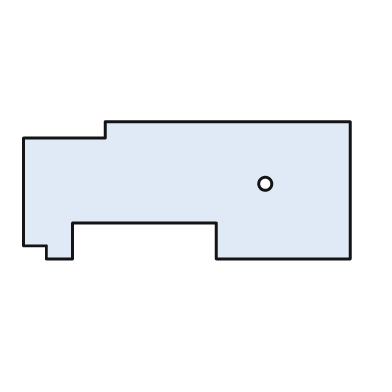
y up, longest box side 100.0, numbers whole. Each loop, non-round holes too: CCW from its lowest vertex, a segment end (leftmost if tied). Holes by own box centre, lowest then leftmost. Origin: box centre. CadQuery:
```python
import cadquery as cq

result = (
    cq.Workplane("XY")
    .moveTo(-43.0, -21.0)
    .lineTo(-35.0, -21.0)
    .lineTo(-35.0, -10.0)
    .lineTo(9.0, -10.0)
    .lineTo(9.0, -21.0)
    .lineTo(50.0, -21.0)
    .lineTo(50.0, 21.0)
    .lineTo(-25.0, 21.0)
    .lineTo(-25.0, 16.0)
    .lineTo(-50.0, 16.0)
    .lineTo(-50.0, -17.0)
    .lineTo(-43.0, -17.0)
    .close()
    .moveTo(24.0, 2.0)
    .circle(2.0)
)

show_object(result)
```